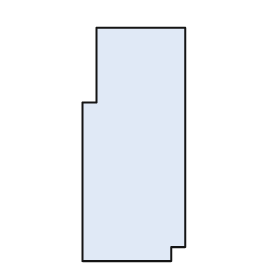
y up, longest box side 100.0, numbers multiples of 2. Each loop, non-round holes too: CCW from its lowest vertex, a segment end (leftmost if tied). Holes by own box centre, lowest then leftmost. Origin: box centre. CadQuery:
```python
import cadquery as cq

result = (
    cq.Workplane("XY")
    .moveTo(-22.0, -50.0)
    .lineTo(16.0, -50.0)
    .lineTo(16.0, -44.0)
    .lineTo(22.0, -44.0)
    .lineTo(22.0, 50.0)
    .lineTo(-16.0, 50.0)
    .lineTo(-16.0, 18.0)
    .lineTo(-22.0, 18.0)
    .close()
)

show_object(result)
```